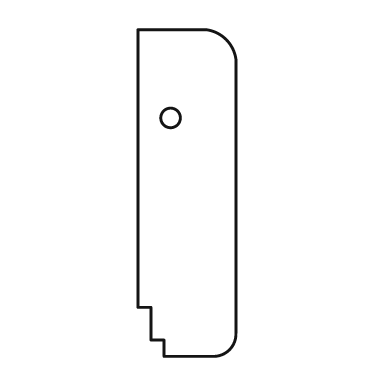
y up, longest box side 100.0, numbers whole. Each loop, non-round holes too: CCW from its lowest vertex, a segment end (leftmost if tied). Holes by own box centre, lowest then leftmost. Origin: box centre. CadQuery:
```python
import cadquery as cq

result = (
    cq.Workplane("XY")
    .moveTo(-7.0, -50.0)
    .lineTo(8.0, -50.0)
    .threePointArc((13.0, -48.0), (15.0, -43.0))
    .lineTo(15.0, 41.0)
    .threePointArc((12.0, 47.0), (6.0, 50.0))
    .lineTo(-15.0, 50.0)
    .lineTo(-15.0, -35.0)
    .lineTo(-11.0, -35.0)
    .lineTo(-11.0, -45.0)
    .lineTo(-7.0, -45.0)
    .close()
    .moveTo(-5.0, 23.0)
    .circle(3.0)
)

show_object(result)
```